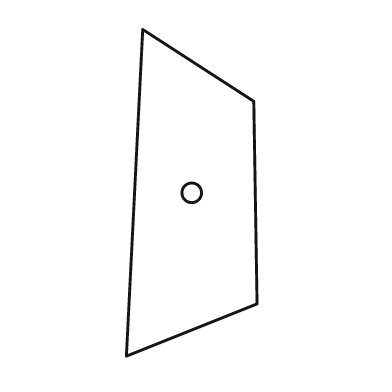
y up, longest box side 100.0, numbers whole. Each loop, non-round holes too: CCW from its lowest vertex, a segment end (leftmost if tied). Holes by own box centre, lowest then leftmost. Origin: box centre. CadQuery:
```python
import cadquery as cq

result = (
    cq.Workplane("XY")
    .moveTo(-20.0, -50.0)
    .lineTo(20.0, -34.0)
    .lineTo(19.0, 28.0)
    .lineTo(-15.0, 50.0)
    .close()
    .moveTo(0.0, 0.0)
    .circle(3.0)
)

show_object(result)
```